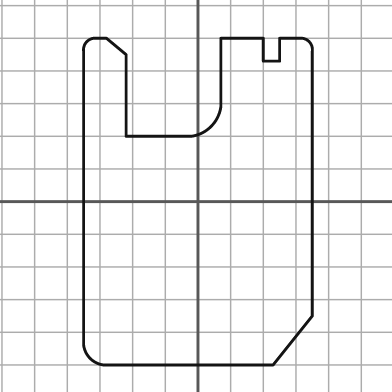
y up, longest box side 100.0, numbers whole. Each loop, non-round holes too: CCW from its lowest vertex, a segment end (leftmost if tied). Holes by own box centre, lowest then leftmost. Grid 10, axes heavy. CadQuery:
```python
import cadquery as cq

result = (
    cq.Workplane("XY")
    .moveTo(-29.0, -50.0)
    .lineTo(23.0, -50.0)
    .lineTo(35.0, -35.0)
    .lineTo(35.0, 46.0)
    .threePointArc((34.0, 49.0), (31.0, 50.0))
    .lineTo(25.0, 50.0)
    .lineTo(25.0, 43.0)
    .lineTo(20.0, 43.0)
    .lineTo(20.0, 50.0)
    .lineTo(7.0, 50.0)
    .lineTo(7.0, 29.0)
    .threePointArc((4.0, 23.0), (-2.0, 20.0))
    .lineTo(-22.0, 20.0)
    .lineTo(-22.0, 45.0)
    .lineTo(-28.0, 50.0)
    .lineTo(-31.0, 50.0)
    .threePointArc((-34.0, 49.0), (-35.0, 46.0))
    .lineTo(-35.0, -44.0)
    .threePointArc((-33.0, -48.0), (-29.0, -50.0))
    .close()
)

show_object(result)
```